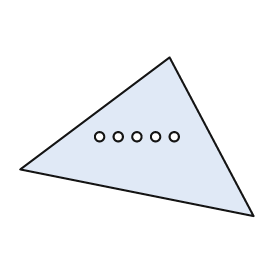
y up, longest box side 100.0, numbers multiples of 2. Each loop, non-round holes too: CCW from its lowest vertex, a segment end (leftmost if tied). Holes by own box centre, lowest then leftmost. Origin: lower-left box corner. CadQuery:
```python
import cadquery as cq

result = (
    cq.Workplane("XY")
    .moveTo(100.0, 0.0)
    .lineTo(64.0, 68.0)
    .lineTo(0.0, 20.0)
    .close()
    .moveTo(34.0, 34.0)
    .circle(2.0)
    .moveTo(42.0, 34.0)
    .circle(2.0)
    .moveTo(50.0, 34.0)
    .circle(2.0)
    .moveTo(58.0, 34.0)
    .circle(2.0)
    .moveTo(66.0, 34.0)
    .circle(2.0)
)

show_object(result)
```